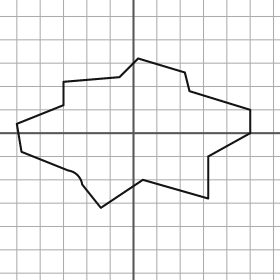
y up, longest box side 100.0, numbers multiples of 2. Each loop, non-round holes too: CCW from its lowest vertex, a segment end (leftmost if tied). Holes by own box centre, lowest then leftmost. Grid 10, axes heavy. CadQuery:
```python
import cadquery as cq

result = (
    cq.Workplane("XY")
    .moveTo(-14.0, -32.0)
    .lineTo(4.0, -20.0)
    .lineTo(32.0, -28.0)
    .lineTo(32.0, -10.0)
    .lineTo(50.0, 0.0)
    .lineTo(50.0, 10.0)
    .lineTo(24.0, 18.0)
    .lineTo(22.0, 26.0)
    .lineTo(2.0, 32.0)
    .lineTo(-6.0, 24.0)
    .lineTo(-30.0, 22.0)
    .lineTo(-30.0, 12.0)
    .lineTo(-50.0, 4.0)
    .lineTo(-48.0, -8.0)
    .lineTo(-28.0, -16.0)
    .threePointArc((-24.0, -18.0), (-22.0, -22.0))
    .close()
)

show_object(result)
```